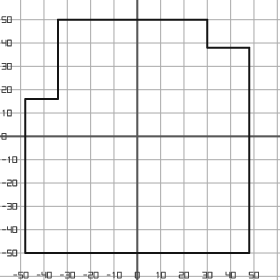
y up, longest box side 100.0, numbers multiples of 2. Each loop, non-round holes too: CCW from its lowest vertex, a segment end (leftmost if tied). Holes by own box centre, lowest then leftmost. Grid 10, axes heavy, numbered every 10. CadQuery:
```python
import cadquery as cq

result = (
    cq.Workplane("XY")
    .moveTo(-48.0, -50.0)
    .lineTo(48.0, -50.0)
    .lineTo(48.0, 38.0)
    .lineTo(30.0, 38.0)
    .lineTo(30.0, 50.0)
    .lineTo(-34.0, 50.0)
    .lineTo(-34.0, 16.0)
    .lineTo(-48.0, 16.0)
    .close()
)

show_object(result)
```